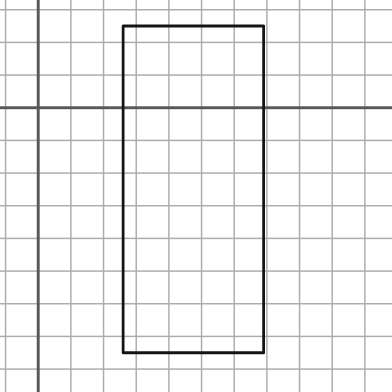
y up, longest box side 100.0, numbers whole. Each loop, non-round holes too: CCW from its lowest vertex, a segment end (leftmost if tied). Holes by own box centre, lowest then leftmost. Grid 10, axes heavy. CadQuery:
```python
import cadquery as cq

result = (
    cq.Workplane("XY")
    .moveTo(26.0, -75.0)
    .lineTo(69.0, -75.0)
    .lineTo(69.0, 25.0)
    .lineTo(26.0, 25.0)
    .close()
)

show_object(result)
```